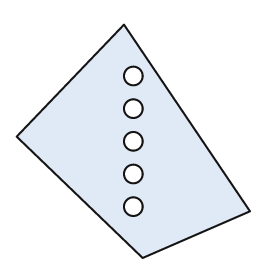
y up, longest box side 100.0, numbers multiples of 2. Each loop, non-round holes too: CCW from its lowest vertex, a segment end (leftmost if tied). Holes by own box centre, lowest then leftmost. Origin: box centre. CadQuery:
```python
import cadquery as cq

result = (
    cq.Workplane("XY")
    .moveTo(4.0, -50.0)
    .lineTo(50.0, -30.0)
    .lineTo(-4.0, 50.0)
    .lineTo(-50.0, 2.0)
    .close()
    .moveTo(0.0, -28.0)
    .circle(4.0)
    .moveTo(0.0, -14.0)
    .circle(4.0)
    .moveTo(0.0, 0.0)
    .circle(4.0)
    .moveTo(0.0, 14.0)
    .circle(4.0)
    .moveTo(0.0, 28.0)
    .circle(4.0)
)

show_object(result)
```